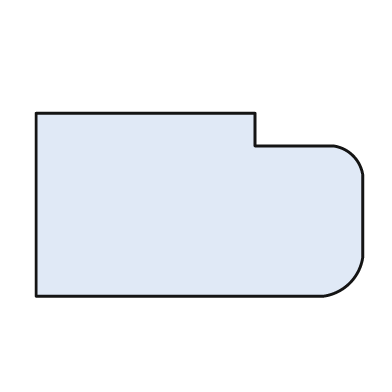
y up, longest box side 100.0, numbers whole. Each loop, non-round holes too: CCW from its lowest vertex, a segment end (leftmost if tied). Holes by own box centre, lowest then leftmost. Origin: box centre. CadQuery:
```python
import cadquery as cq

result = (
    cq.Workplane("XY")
    .moveTo(-50.0, -28.0)
    .lineTo(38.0, -28.0)
    .threePointArc((46.0, -24.0), (50.0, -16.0))
    .lineTo(50.0, 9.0)
    .threePointArc((47.0, 15.0), (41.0, 18.0))
    .lineTo(17.0, 18.0)
    .lineTo(17.0, 28.0)
    .lineTo(-50.0, 28.0)
    .close()
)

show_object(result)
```